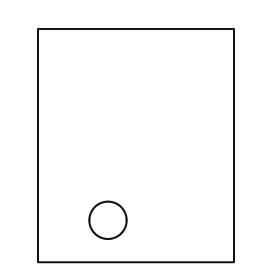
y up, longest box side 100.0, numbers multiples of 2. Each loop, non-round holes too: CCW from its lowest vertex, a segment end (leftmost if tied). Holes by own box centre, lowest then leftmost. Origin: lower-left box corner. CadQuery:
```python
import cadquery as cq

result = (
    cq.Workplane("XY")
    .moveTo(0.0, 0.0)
    .lineTo(84.0, 0.0)
    .lineTo(84.0, 100.0)
    .lineTo(0.0, 100.0)
    .close()
    .moveTo(30.0, 18.0)
    .circle(8.0)
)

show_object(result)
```